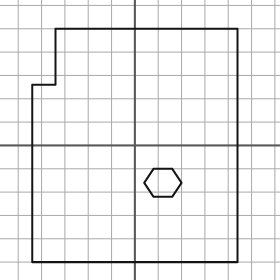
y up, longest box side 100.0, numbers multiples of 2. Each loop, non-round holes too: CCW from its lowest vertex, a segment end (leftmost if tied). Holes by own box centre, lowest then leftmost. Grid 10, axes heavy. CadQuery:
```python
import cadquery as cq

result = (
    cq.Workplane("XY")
    .moveTo(-44.0, -50.0)
    .lineTo(44.0, -50.0)
    .lineTo(44.0, 50.0)
    .lineTo(-34.0, 50.0)
    .lineTo(-34.0, 26.0)
    .lineTo(-44.0, 26.0)
    .close()
    .moveTo(8.0, -22.0)
    .lineTo(16.0, -22.0)
    .lineTo(20.0, -16.0)
    .lineTo(16.0, -10.0)
    .lineTo(8.0, -10.0)
    .lineTo(4.0, -16.0)
    .close()
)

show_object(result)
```